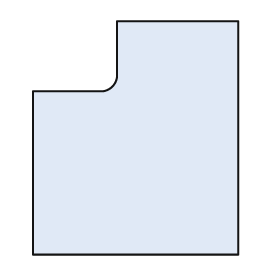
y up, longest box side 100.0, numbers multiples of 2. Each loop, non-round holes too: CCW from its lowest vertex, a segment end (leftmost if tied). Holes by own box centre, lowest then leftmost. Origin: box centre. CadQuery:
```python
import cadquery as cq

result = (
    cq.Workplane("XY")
    .moveTo(-44.0, -50.0)
    .lineTo(44.0, -50.0)
    .lineTo(44.0, 50.0)
    .lineTo(-8.0, 50.0)
    .lineTo(-8.0, 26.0)
    .threePointArc((-10.0, 22.0), (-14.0, 20.0))
    .lineTo(-44.0, 20.0)
    .close()
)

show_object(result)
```